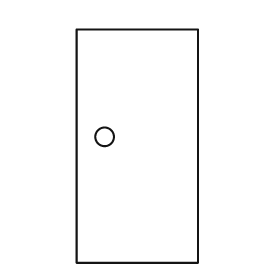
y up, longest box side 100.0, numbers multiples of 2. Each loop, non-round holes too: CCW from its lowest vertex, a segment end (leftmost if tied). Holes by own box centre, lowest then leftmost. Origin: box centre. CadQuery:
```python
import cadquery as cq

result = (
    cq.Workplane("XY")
    .moveTo(-26.0, -50.0)
    .lineTo(26.0, -50.0)
    .lineTo(26.0, 50.0)
    .lineTo(-26.0, 50.0)
    .close()
    .moveTo(-14.0, 4.0)
    .circle(4.0)
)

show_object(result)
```